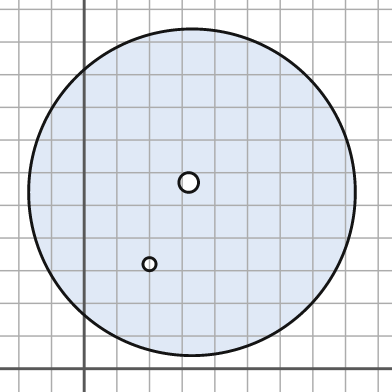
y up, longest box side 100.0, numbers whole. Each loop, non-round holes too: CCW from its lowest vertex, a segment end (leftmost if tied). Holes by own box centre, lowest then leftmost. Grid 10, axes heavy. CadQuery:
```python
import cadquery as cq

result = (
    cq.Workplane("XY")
    .moveTo(33.0, 54.0)
    .circle(50.0)
    .moveTo(20.0, 32.0)
    .circle(2.0)
    .moveTo(32.0, 57.0)
    .circle(3.0)
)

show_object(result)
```